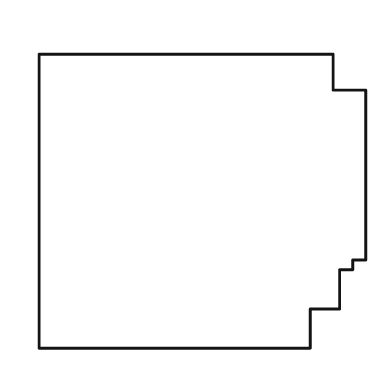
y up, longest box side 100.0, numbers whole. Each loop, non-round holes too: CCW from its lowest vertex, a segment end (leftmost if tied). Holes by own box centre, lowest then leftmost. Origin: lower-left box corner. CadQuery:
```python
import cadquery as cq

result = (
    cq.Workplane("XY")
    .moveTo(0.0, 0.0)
    .lineTo(83.0, 0.0)
    .lineTo(83.0, 12.0)
    .lineTo(92.0, 12.0)
    .lineTo(92.0, 24.0)
    .lineTo(96.0, 24.0)
    .lineTo(96.0, 27.0)
    .lineTo(100.0, 27.0)
    .lineTo(100.0, 79.0)
    .lineTo(90.0, 79.0)
    .lineTo(90.0, 90.0)
    .lineTo(0.0, 90.0)
    .close()
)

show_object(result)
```